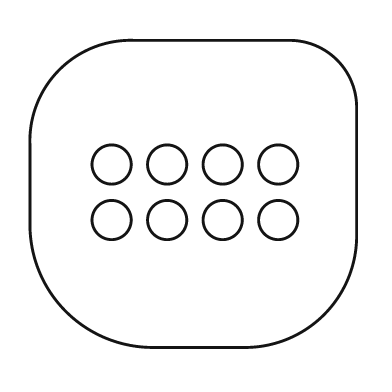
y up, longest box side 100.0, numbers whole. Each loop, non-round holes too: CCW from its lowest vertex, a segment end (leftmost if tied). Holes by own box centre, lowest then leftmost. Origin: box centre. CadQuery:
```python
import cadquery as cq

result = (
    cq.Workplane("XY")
    .moveTo(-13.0, -47.0)
    .lineTo(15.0, -47.0)
    .threePointArc((40.0, -37.0), (50.0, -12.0))
    .lineTo(50.0, 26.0)
    .threePointArc((44.0, 41.0), (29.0, 47.0))
    .lineTo(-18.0, 47.0)
    .threePointArc((-41.0, 38.0), (-50.0, 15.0))
    .lineTo(-50.0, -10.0)
    .threePointArc((-39.0, -36.0), (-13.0, -47.0))
    .close()
    .moveTo(-25.0, -8.0)
    .circle(6.0)
    .moveTo(-8.0, -8.0)
    .circle(6.0)
    .moveTo(9.0, -8.0)
    .circle(6.0)
    .moveTo(26.0, -8.0)
    .circle(6.0)
    .moveTo(-25.0, 9.0)
    .circle(6.0)
    .moveTo(-8.0, 9.0)
    .circle(6.0)
    .moveTo(9.0, 9.0)
    .circle(6.0)
    .moveTo(26.0, 9.0)
    .circle(6.0)
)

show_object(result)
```